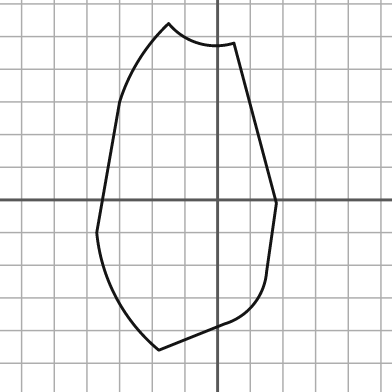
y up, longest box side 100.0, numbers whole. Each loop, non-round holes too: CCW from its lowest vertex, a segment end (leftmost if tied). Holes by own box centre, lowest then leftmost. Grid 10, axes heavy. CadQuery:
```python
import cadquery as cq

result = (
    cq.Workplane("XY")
    .moveTo(-18.0, -46.0)
    .lineTo(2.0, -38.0)
    .threePointArc((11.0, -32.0), (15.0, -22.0))
    .lineTo(18.0, -1.0)
    .lineTo(5.0, 48.0)
    .threePointArc((-6.0, 48.0), (-15.0, 54.0))
    .threePointArc((-24.0, 43.0), (-30.0, 30.0))
    .lineTo(-37.0, -10.0)
    .threePointArc((-31.0, -30.0), (-18.0, -46.0))
    .close()
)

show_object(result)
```